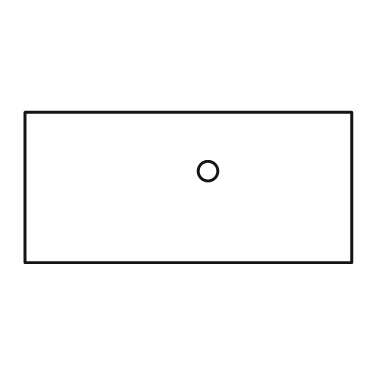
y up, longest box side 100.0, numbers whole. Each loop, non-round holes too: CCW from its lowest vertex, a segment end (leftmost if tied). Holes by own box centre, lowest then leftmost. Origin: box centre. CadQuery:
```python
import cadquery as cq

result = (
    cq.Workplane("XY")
    .moveTo(-50.0, -23.0)
    .lineTo(50.0, -23.0)
    .lineTo(50.0, 23.0)
    .lineTo(-50.0, 23.0)
    .close()
    .moveTo(6.0, 5.0)
    .circle(3.0)
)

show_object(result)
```